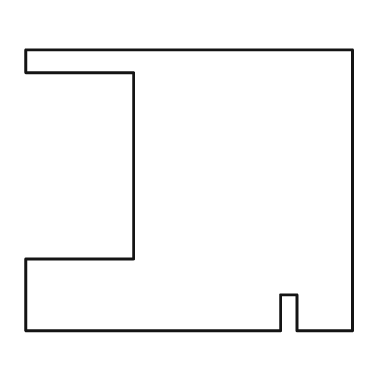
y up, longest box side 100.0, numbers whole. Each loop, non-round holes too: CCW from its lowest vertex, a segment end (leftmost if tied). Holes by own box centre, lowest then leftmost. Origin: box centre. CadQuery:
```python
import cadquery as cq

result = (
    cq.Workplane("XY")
    .moveTo(-50.0, -43.0)
    .lineTo(28.0, -43.0)
    .lineTo(28.0, -32.0)
    .lineTo(33.0, -32.0)
    .lineTo(33.0, -43.0)
    .lineTo(50.0, -43.0)
    .lineTo(50.0, 43.0)
    .lineTo(-50.0, 43.0)
    .lineTo(-50.0, 36.0)
    .lineTo(-17.0, 36.0)
    .lineTo(-17.0, -21.0)
    .lineTo(-50.0, -21.0)
    .close()
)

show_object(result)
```